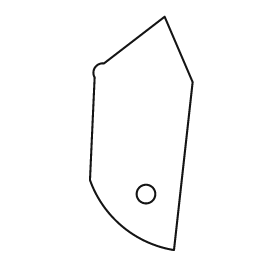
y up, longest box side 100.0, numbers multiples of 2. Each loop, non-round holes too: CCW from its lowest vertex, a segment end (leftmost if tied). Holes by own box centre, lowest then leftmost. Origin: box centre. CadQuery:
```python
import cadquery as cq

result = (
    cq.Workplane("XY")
    .moveTo(14.0, -50.0)
    .lineTo(22.0, 22.0)
    .lineTo(10.0, 50.0)
    .lineTo(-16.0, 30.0)
    .threePointArc((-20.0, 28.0), (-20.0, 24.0))
    .lineTo(-22.0, -20.0)
    .threePointArc((-8.0, -40.0), (14.0, -50.0))
    .close()
    .moveTo(2.0, -26.0)
    .circle(4.0)
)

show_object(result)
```